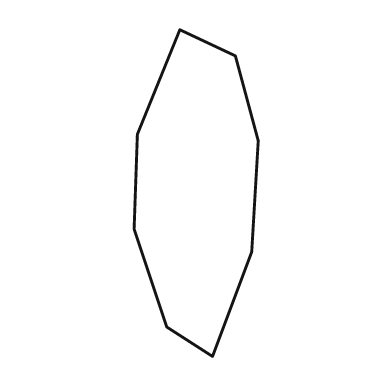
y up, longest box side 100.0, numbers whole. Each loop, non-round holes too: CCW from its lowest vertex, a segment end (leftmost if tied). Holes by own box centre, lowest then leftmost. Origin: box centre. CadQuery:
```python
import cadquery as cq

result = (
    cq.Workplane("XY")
    .moveTo(5.0, -50.0)
    .lineTo(17.0, -18.0)
    .lineTo(19.0, 16.0)
    .lineTo(12.0, 42.0)
    .lineTo(-5.0, 50.0)
    .lineTo(-18.0, 18.0)
    .lineTo(-19.0, -11.0)
    .lineTo(-9.0, -41.0)
    .close()
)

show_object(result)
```